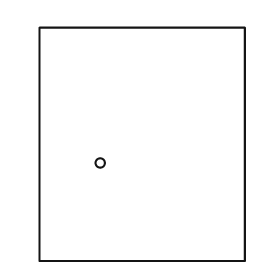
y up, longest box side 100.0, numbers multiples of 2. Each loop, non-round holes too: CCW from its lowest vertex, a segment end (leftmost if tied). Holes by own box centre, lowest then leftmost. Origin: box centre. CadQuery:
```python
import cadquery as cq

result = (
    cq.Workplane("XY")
    .moveTo(-44.0, -50.0)
    .lineTo(44.0, -50.0)
    .lineTo(44.0, 50.0)
    .lineTo(-44.0, 50.0)
    .close()
    .moveTo(-18.0, -8.0)
    .circle(2.0)
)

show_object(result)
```